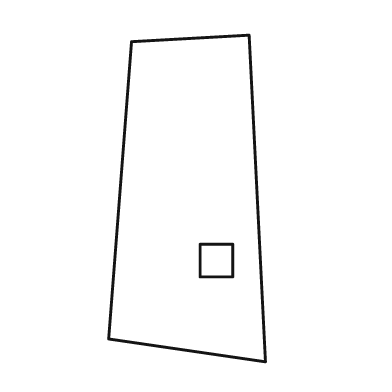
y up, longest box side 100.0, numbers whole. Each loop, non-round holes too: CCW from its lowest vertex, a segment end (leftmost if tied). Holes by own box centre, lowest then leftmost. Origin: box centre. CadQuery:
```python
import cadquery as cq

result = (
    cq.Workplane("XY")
    .moveTo(24.0, -50.0)
    .lineTo(19.0, 50.0)
    .lineTo(-17.0, 48.0)
    .lineTo(-24.0, -43.0)
    .close()
    .moveTo(4.0, -24.0)
    .lineTo(14.0, -24.0)
    .lineTo(14.0, -14.0)
    .lineTo(4.0, -14.0)
    .close()
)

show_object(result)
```